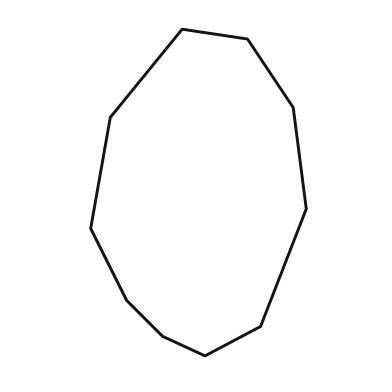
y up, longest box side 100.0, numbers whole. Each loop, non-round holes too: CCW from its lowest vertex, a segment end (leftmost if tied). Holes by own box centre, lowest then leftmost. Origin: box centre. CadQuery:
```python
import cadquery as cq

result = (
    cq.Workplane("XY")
    .moveTo(2.0, -50.0)
    .lineTo(19.0, -41.0)
    .lineTo(33.0, -5.0)
    .lineTo(29.0, 26.0)
    .lineTo(15.0, 47.0)
    .lineTo(-5.0, 50.0)
    .lineTo(-27.0, 23.0)
    .lineTo(-33.0, -11.0)
    .lineTo(-22.0, -33.0)
    .lineTo(-11.0, -44.0)
    .close()
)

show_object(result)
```